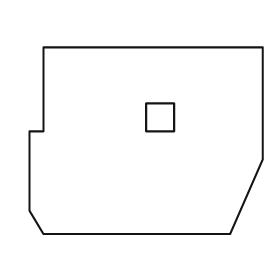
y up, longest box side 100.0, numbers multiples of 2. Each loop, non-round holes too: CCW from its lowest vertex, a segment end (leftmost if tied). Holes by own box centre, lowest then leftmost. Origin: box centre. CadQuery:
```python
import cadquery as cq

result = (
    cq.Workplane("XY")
    .moveTo(-44.0, -40.0)
    .lineTo(36.0, -40.0)
    .lineTo(50.0, -8.0)
    .lineTo(50.0, 40.0)
    .lineTo(-44.0, 40.0)
    .lineTo(-44.0, 4.0)
    .lineTo(-50.0, 4.0)
    .lineTo(-50.0, -30.0)
    .close()
    .moveTo(0.0, 4.0)
    .lineTo(12.0, 4.0)
    .lineTo(12.0, 16.0)
    .lineTo(0.0, 16.0)
    .close()
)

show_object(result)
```